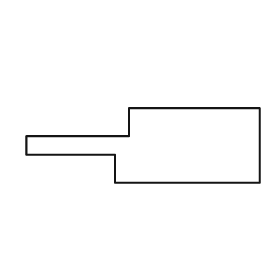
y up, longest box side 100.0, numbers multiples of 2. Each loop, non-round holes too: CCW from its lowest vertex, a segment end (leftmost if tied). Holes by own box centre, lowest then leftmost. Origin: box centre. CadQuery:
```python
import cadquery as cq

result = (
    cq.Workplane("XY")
    .moveTo(-12.0, -16.0)
    .lineTo(50.0, -16.0)
    .lineTo(50.0, 16.0)
    .lineTo(-6.0, 16.0)
    .lineTo(-6.0, 4.0)
    .lineTo(-50.0, 4.0)
    .lineTo(-50.0, -4.0)
    .lineTo(-12.0, -4.0)
    .close()
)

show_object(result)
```